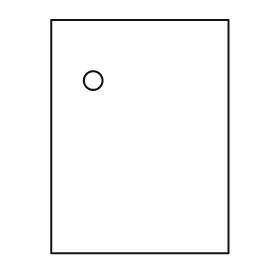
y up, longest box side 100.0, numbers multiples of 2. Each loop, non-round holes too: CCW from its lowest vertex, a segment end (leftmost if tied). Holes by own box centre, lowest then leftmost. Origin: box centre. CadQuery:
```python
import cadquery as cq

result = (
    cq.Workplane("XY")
    .moveTo(-38.0, -50.0)
    .lineTo(38.0, -50.0)
    .lineTo(38.0, 50.0)
    .lineTo(-38.0, 50.0)
    .close()
    .moveTo(-20.0, 24.0)
    .circle(4.0)
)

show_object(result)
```